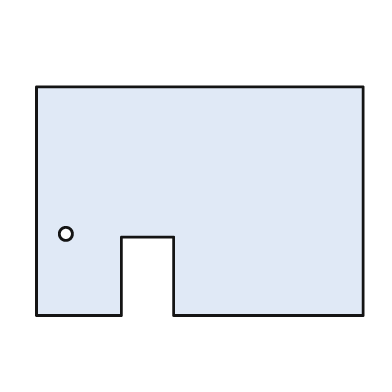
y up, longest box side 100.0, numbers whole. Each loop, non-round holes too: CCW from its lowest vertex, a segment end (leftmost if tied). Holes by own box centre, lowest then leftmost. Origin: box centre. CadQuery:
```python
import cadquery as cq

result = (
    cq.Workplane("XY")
    .moveTo(-50.0, -35.0)
    .lineTo(-24.0, -35.0)
    .lineTo(-24.0, -11.0)
    .lineTo(-8.0, -11.0)
    .lineTo(-8.0, -35.0)
    .lineTo(50.0, -35.0)
    .lineTo(50.0, 35.0)
    .lineTo(-50.0, 35.0)
    .close()
    .moveTo(-41.0, -10.0)
    .circle(2.0)
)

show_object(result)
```